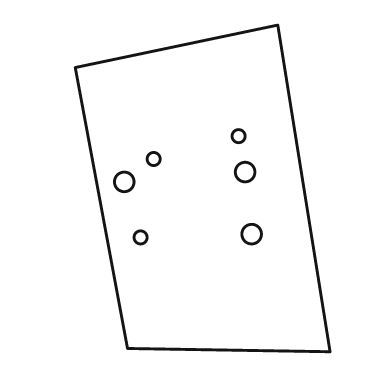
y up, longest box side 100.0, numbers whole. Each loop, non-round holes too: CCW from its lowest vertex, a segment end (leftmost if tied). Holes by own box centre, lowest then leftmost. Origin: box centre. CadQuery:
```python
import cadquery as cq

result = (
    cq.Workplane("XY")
    .moveTo(39.0, -50.0)
    .lineTo(23.0, 50.0)
    .lineTo(-39.0, 37.0)
    .lineTo(-23.0, -49.0)
    .close()
    .moveTo(-19.0, -15.0)
    .circle(2.0)
    .moveTo(15.0, -14.0)
    .circle(3.0)
    .moveTo(-24.0, 2.0)
    .circle(3.0)
    .moveTo(13.0, 5.0)
    .circle(3.0)
    .moveTo(-15.0, 9.0)
    .circle(2.0)
    .moveTo(11.0, 16.0)
    .circle(2.0)
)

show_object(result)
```